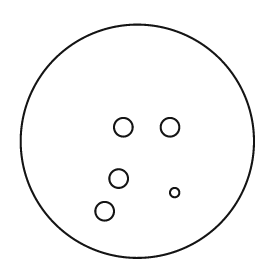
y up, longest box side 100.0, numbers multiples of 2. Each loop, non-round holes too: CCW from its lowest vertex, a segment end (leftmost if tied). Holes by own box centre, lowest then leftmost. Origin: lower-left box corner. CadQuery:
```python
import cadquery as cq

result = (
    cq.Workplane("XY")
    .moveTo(50.0, 50.0)
    .circle(50.0)
    .moveTo(36.0, 20.0)
    .circle(4.0)
    .moveTo(66.0, 28.0)
    .circle(2.0)
    .moveTo(42.0, 34.0)
    .circle(4.0)
    .moveTo(44.0, 56.0)
    .circle(4.0)
    .moveTo(64.0, 56.0)
    .circle(4.0)
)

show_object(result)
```